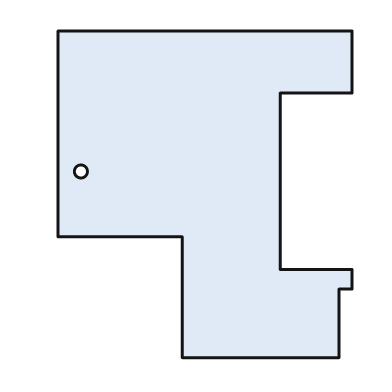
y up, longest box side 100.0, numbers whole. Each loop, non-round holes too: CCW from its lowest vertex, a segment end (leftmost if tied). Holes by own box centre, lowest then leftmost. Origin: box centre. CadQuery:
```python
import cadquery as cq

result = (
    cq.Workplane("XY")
    .moveTo(-7.0, -50.0)
    .lineTo(41.0, -50.0)
    .lineTo(41.0, -29.0)
    .lineTo(45.0, -29.0)
    .lineTo(45.0, -23.0)
    .lineTo(23.0, -23.0)
    .lineTo(23.0, 31.0)
    .lineTo(45.0, 31.0)
    .lineTo(45.0, 50.0)
    .lineTo(-45.0, 50.0)
    .lineTo(-45.0, -13.0)
    .lineTo(-7.0, -13.0)
    .close()
    .moveTo(-38.0, 7.0)
    .circle(2.0)
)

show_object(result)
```